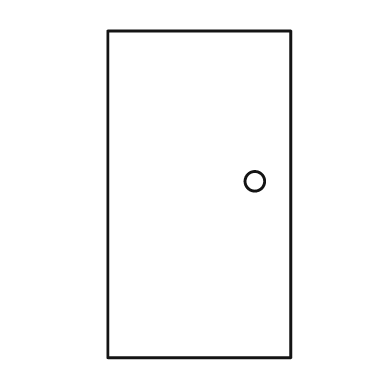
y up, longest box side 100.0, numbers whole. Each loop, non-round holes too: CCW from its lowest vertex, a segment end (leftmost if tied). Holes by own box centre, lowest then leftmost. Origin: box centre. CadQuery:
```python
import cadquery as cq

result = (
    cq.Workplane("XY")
    .moveTo(-28.0, -50.0)
    .lineTo(28.0, -50.0)
    .lineTo(28.0, 50.0)
    .lineTo(-28.0, 50.0)
    .close()
    .moveTo(17.0, 4.0)
    .circle(3.0)
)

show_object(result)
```